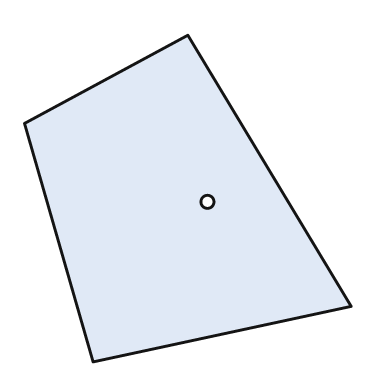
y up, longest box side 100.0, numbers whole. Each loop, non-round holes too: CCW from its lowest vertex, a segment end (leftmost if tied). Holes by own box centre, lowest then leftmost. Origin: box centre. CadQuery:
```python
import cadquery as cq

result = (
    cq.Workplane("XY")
    .moveTo(-29.0, -50.0)
    .lineTo(50.0, -33.0)
    .lineTo(0.0, 50.0)
    .lineTo(-50.0, 23.0)
    .close()
    .moveTo(6.0, -1.0)
    .circle(2.0)
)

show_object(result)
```